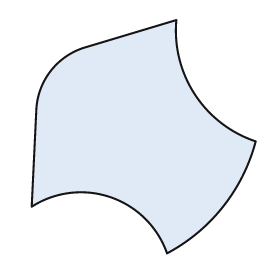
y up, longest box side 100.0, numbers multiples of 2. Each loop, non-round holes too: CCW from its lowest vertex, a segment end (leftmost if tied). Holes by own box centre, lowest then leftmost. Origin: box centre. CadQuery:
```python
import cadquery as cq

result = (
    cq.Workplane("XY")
    .moveTo(10.0, -50.0)
    .threePointArc((34.0, -30.0), (48.0, -2.0))
    .threePointArc((22.0, 18.0), (14.0, 50.0))
    .lineTo(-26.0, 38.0)
    .threePointArc((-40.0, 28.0), (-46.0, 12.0))
    .lineTo(-48.0, -30.0)
    .threePointArc((-14.0, -26.0), (10.0, -50.0))
    .close()
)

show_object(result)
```